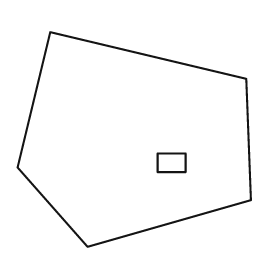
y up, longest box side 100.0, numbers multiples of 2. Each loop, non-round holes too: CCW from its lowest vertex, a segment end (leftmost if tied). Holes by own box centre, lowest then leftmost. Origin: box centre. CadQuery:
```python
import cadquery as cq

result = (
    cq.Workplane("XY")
    .moveTo(-20.0, -46.0)
    .lineTo(50.0, -26.0)
    .lineTo(48.0, 26.0)
    .lineTo(-36.0, 46.0)
    .lineTo(-50.0, -12.0)
    .close()
    .moveTo(10.0, -14.0)
    .lineTo(22.0, -14.0)
    .lineTo(22.0, -6.0)
    .lineTo(10.0, -6.0)
    .close()
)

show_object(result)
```